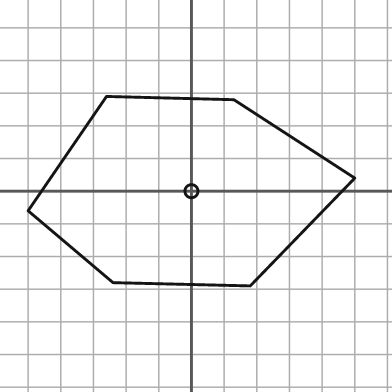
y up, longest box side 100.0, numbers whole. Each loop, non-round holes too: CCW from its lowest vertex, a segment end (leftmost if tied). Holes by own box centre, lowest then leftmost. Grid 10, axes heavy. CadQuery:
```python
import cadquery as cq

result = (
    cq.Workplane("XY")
    .moveTo(18.0, -29.0)
    .lineTo(50.0, 4.0)
    .lineTo(13.0, 28.0)
    .lineTo(-26.0, 29.0)
    .lineTo(-50.0, -6.0)
    .lineTo(-24.0, -28.0)
    .close()
    .moveTo(0.0, 0.0)
    .circle(2.0)
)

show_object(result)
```